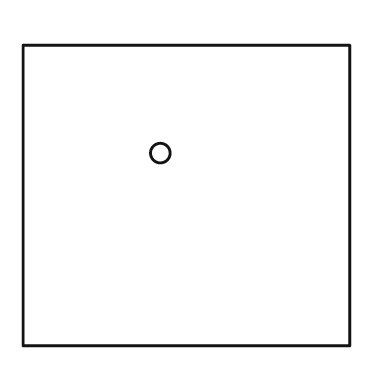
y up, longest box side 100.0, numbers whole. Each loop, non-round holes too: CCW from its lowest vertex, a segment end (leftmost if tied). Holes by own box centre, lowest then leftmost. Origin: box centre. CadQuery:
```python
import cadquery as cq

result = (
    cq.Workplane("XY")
    .moveTo(-50.0, -46.0)
    .lineTo(50.0, -46.0)
    .lineTo(50.0, 46.0)
    .lineTo(-50.0, 46.0)
    .close()
    .moveTo(-8.0, 13.0)
    .circle(3.0)
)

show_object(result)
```